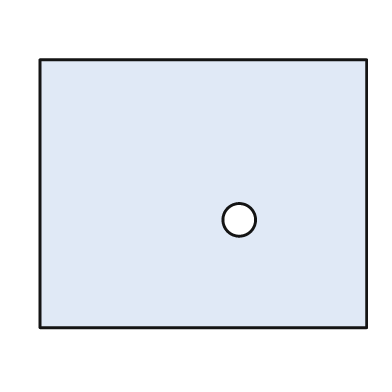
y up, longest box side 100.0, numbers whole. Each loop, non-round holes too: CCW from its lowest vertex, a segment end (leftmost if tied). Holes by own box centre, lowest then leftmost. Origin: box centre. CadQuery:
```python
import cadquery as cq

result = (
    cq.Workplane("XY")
    .moveTo(-50.0, -41.0)
    .lineTo(50.0, -41.0)
    .lineTo(50.0, 41.0)
    .lineTo(-50.0, 41.0)
    .close()
    .moveTo(11.0, -8.0)
    .circle(5.0)
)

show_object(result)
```